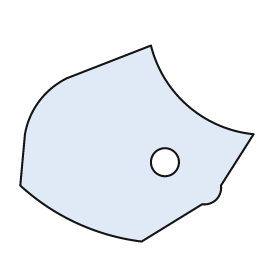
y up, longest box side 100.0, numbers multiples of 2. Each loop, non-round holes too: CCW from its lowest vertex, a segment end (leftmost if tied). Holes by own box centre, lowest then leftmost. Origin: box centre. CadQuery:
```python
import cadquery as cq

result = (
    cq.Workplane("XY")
    .moveTo(2.0, -42.0)
    .lineTo(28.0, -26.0)
    .threePointArc((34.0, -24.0), (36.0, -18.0))
    .lineTo(50.0, 4.0)
    .threePointArc((22.0, 16.0), (6.0, 42.0))
    .lineTo(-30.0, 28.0)
    .threePointArc((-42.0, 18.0), (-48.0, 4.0))
    .lineTo(-50.0, -18.0)
    .threePointArc((-26.0, -34.0), (2.0, -42.0))
    .close()
    .moveTo(12.0, -8.0)
    .circle(6.0)
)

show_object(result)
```